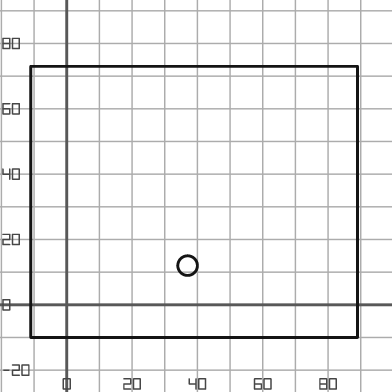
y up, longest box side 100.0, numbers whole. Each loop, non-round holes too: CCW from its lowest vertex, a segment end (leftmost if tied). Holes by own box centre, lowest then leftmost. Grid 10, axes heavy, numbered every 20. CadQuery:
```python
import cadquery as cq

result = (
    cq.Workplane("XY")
    .moveTo(-11.0, -10.0)
    .lineTo(89.0, -10.0)
    .lineTo(89.0, 73.0)
    .lineTo(-11.0, 73.0)
    .close()
    .moveTo(37.0, 12.0)
    .circle(3.0)
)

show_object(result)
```